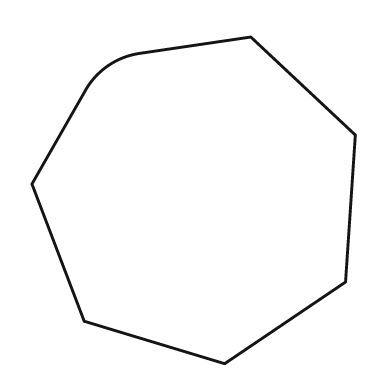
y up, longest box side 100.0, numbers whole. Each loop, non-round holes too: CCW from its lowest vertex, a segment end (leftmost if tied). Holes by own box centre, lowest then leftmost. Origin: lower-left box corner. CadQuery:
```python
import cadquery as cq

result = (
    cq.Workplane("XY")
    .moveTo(59.0, 0.0)
    .lineTo(96.0, 25.0)
    .lineTo(99.0, 70.0)
    .lineTo(67.0, 100.0)
    .lineTo(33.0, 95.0)
    .threePointArc((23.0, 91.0), (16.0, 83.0))
    .lineTo(0.0, 55.0)
    .lineTo(16.0, 13.0)
    .close()
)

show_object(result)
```